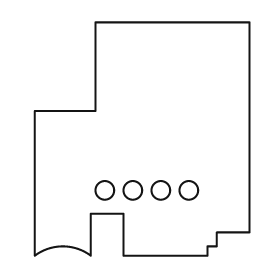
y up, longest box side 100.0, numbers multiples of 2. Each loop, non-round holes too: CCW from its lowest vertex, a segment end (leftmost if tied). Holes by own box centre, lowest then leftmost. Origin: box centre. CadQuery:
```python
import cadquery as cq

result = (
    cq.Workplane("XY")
    .moveTo(-46.0, -50.0)
    .threePointArc((-34.0, -46.0), (-22.0, -50.0))
    .lineTo(-22.0, -32.0)
    .lineTo(-8.0, -32.0)
    .lineTo(-8.0, -50.0)
    .lineTo(28.0, -50.0)
    .lineTo(28.0, -46.0)
    .lineTo(32.0, -46.0)
    .lineTo(32.0, -40.0)
    .lineTo(46.0, -40.0)
    .lineTo(46.0, 50.0)
    .lineTo(-20.0, 50.0)
    .lineTo(-20.0, 12.0)
    .lineTo(-46.0, 12.0)
    .close()
    .moveTo(-16.0, -22.0)
    .circle(4.0)
    .moveTo(-4.0, -22.0)
    .circle(4.0)
    .moveTo(8.0, -22.0)
    .circle(4.0)
    .moveTo(20.0, -22.0)
    .circle(4.0)
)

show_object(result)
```